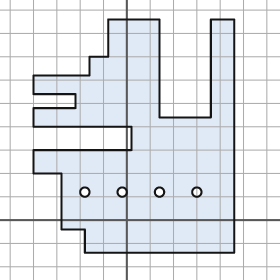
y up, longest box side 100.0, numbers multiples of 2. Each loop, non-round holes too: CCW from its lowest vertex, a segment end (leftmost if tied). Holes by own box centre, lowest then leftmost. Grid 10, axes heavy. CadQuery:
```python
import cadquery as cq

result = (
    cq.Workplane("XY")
    .moveTo(-18.0, -14.0)
    .lineTo(46.0, -14.0)
    .lineTo(46.0, 86.0)
    .lineTo(36.0, 86.0)
    .lineTo(36.0, 44.0)
    .lineTo(14.0, 44.0)
    .lineTo(14.0, 86.0)
    .lineTo(-8.0, 86.0)
    .lineTo(-8.0, 70.0)
    .lineTo(-16.0, 70.0)
    .lineTo(-16.0, 62.0)
    .lineTo(-40.0, 62.0)
    .lineTo(-40.0, 54.0)
    .lineTo(-22.0, 54.0)
    .lineTo(-22.0, 48.0)
    .lineTo(-40.0, 48.0)
    .lineTo(-40.0, 40.0)
    .lineTo(2.0, 40.0)
    .lineTo(2.0, 30.0)
    .lineTo(-40.0, 30.0)
    .lineTo(-40.0, 20.0)
    .lineTo(-28.0, 20.0)
    .lineTo(-28.0, -4.0)
    .lineTo(-18.0, -4.0)
    .close()
    .moveTo(-18.0, 12.0)
    .circle(2.0)
    .moveTo(-2.0, 12.0)
    .circle(2.0)
    .moveTo(14.0, 12.0)
    .circle(2.0)
    .moveTo(30.0, 12.0)
    .circle(2.0)
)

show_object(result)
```